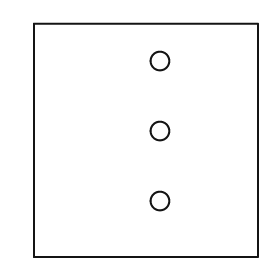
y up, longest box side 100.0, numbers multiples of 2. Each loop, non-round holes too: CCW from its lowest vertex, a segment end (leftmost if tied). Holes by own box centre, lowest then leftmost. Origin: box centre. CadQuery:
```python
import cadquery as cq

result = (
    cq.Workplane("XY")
    .moveTo(-48.0, -50.0)
    .lineTo(48.0, -50.0)
    .lineTo(48.0, 50.0)
    .lineTo(-48.0, 50.0)
    .close()
    .moveTo(6.0, -26.0)
    .circle(4.0)
    .moveTo(6.0, 4.0)
    .circle(4.0)
    .moveTo(6.0, 34.0)
    .circle(4.0)
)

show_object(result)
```